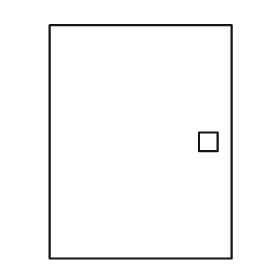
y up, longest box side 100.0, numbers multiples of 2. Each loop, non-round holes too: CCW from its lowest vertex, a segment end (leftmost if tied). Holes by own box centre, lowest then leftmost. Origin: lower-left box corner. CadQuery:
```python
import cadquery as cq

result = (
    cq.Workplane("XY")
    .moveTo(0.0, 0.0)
    .lineTo(78.0, 0.0)
    .lineTo(78.0, 100.0)
    .lineTo(0.0, 100.0)
    .close()
    .moveTo(64.0, 46.0)
    .lineTo(72.0, 46.0)
    .lineTo(72.0, 54.0)
    .lineTo(64.0, 54.0)
    .close()
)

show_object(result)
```